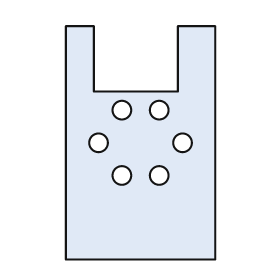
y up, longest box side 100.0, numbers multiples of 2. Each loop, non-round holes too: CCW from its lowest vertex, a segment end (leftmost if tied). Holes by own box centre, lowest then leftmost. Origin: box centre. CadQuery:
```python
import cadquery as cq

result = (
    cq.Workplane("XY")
    .moveTo(-32.0, -50.0)
    .lineTo(32.0, -50.0)
    .lineTo(32.0, 50.0)
    .lineTo(16.0, 50.0)
    .lineTo(16.0, 22.0)
    .lineTo(-20.0, 22.0)
    .lineTo(-20.0, 50.0)
    .lineTo(-32.0, 50.0)
    .close()
    .moveTo(-8.0, -14.0)
    .circle(4.0)
    .moveTo(8.0, -14.0)
    .circle(4.0)
    .moveTo(-18.0, 0.0)
    .circle(4.0)
    .moveTo(18.0, 0.0)
    .circle(4.0)
    .moveTo(-8.0, 14.0)
    .circle(4.0)
    .moveTo(8.0, 14.0)
    .circle(4.0)
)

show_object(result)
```